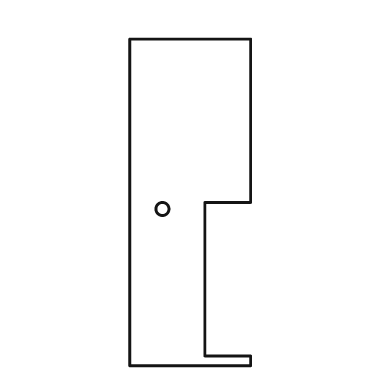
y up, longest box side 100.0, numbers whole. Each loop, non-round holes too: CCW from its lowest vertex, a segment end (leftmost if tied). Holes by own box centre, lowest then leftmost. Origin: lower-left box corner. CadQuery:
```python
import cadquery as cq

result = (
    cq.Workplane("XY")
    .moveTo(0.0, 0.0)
    .lineTo(37.0, 0.0)
    .lineTo(37.0, 3.0)
    .lineTo(23.0, 3.0)
    .lineTo(23.0, 50.0)
    .lineTo(37.0, 50.0)
    .lineTo(37.0, 100.0)
    .lineTo(0.0, 100.0)
    .close()
    .moveTo(10.0, 48.0)
    .circle(2.0)
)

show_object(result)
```